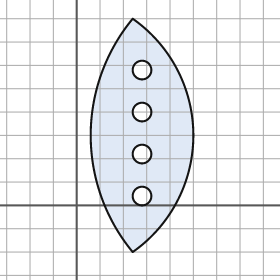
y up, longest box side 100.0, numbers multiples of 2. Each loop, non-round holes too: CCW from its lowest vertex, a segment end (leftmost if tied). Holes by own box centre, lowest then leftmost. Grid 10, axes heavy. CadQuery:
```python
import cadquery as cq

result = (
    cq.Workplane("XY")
    .moveTo(24.0, -20.0)
    .threePointArc((50.0, 30.0), (24.0, 80.0))
    .threePointArc((6.0, 30.0), (24.0, -20.0))
    .close()
    .moveTo(28.0, 4.0)
    .circle(4.0)
    .moveTo(28.0, 22.0)
    .circle(4.0)
    .moveTo(28.0, 40.0)
    .circle(4.0)
    .moveTo(28.0, 58.0)
    .circle(4.0)
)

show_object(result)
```